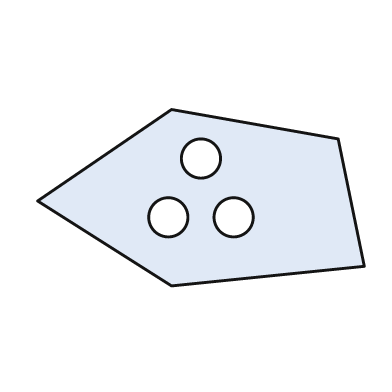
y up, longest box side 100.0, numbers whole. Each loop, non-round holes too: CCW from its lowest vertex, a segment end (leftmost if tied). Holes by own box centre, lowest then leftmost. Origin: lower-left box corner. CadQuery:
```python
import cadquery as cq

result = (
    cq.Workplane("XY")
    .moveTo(41.0, 0.0)
    .lineTo(100.0, 6.0)
    .lineTo(92.0, 45.0)
    .lineTo(41.0, 54.0)
    .lineTo(0.0, 26.0)
    .close()
    .moveTo(40.0, 21.0)
    .circle(6.0)
    .moveTo(60.0, 21.0)
    .circle(6.0)
    .moveTo(50.0, 39.0)
    .circle(6.0)
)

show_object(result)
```